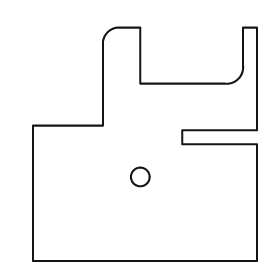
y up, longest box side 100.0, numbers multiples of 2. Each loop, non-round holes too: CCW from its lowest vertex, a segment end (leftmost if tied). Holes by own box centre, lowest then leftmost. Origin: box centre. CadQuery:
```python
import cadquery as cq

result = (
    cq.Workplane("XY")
    .moveTo(-48.0, -50.0)
    .lineTo(48.0, -50.0)
    .lineTo(48.0, 0.0)
    .lineTo(16.0, 0.0)
    .lineTo(16.0, 6.0)
    .lineTo(48.0, 6.0)
    .lineTo(48.0, 50.0)
    .lineTo(42.0, 50.0)
    .lineTo(42.0, 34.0)
    .threePointArc((40.0, 28.0), (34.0, 26.0))
    .lineTo(-2.0, 26.0)
    .lineTo(-2.0, 50.0)
    .lineTo(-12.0, 50.0)
    .threePointArc((-16.0, 48.0), (-18.0, 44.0))
    .lineTo(-18.0, 8.0)
    .lineTo(-48.0, 8.0)
    .close()
    .moveTo(-2.0, -14.0)
    .circle(4.0)
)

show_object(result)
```